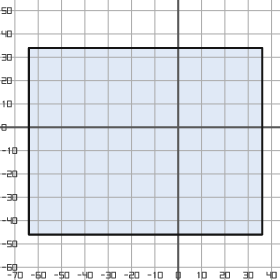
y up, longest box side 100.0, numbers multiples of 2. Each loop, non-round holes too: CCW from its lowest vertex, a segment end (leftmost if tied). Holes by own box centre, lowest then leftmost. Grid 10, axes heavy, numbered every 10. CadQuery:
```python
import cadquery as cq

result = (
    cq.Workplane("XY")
    .moveTo(-64.0, -46.0)
    .lineTo(36.0, -46.0)
    .lineTo(36.0, 34.0)
    .lineTo(-64.0, 34.0)
    .close()
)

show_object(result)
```